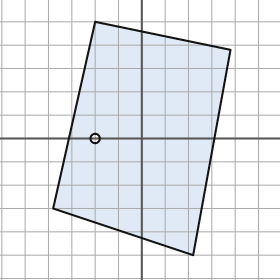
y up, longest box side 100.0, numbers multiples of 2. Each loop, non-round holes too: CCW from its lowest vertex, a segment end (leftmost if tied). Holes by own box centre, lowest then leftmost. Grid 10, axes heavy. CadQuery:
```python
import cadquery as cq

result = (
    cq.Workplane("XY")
    .moveTo(22.0, -50.0)
    .lineTo(38.0, 38.0)
    .lineTo(-20.0, 50.0)
    .lineTo(-38.0, -30.0)
    .close()
    .moveTo(-20.0, 0.0)
    .circle(2.0)
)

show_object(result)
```